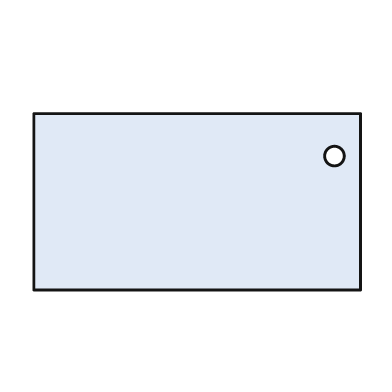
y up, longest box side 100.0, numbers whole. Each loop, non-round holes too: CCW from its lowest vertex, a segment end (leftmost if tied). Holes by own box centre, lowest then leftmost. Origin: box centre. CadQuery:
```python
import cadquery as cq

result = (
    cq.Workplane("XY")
    .moveTo(-50.0, -27.0)
    .lineTo(50.0, -27.0)
    .lineTo(50.0, 27.0)
    .lineTo(-50.0, 27.0)
    .close()
    .moveTo(42.0, 14.0)
    .circle(3.0)
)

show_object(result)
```